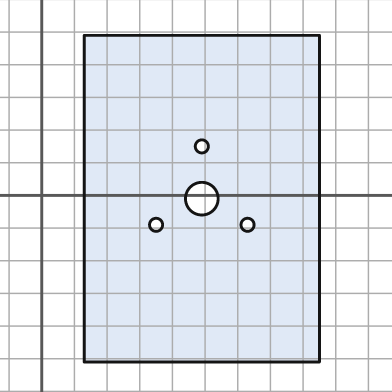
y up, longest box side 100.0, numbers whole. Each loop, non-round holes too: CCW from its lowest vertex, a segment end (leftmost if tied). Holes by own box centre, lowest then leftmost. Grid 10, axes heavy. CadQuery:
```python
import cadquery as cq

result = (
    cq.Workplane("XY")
    .moveTo(13.0, -51.0)
    .lineTo(85.0, -51.0)
    .lineTo(85.0, 49.0)
    .lineTo(13.0, 49.0)
    .close()
    .moveTo(35.0, -9.0)
    .circle(2.0)
    .moveTo(63.0, -9.0)
    .circle(2.0)
    .moveTo(49.0, -1.0)
    .circle(5.0)
    .moveTo(49.0, 15.0)
    .circle(2.0)
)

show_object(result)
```